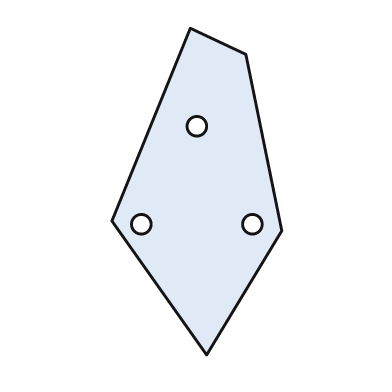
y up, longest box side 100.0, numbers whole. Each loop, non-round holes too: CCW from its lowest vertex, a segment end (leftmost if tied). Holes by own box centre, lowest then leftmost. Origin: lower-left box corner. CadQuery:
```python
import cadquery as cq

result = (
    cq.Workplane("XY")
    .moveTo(29.0, 0.0)
    .lineTo(52.0, 38.0)
    .lineTo(41.0, 92.0)
    .lineTo(24.0, 100.0)
    .lineTo(0.0, 41.0)
    .close()
    .moveTo(9.0, 40.0)
    .circle(3.0)
    .moveTo(43.0, 40.0)
    .circle(3.0)
    .moveTo(26.0, 70.0)
    .circle(3.0)
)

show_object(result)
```